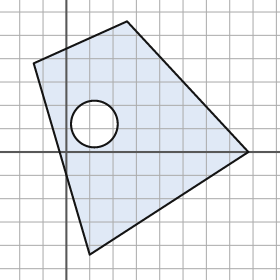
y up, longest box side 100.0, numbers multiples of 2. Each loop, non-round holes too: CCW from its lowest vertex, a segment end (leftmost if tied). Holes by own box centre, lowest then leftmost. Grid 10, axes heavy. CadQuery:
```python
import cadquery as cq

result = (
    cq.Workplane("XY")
    .moveTo(10.0, -44.0)
    .lineTo(78.0, 0.0)
    .lineTo(26.0, 56.0)
    .lineTo(-14.0, 38.0)
    .close()
    .moveTo(12.0, 12.0)
    .circle(10.0)
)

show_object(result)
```